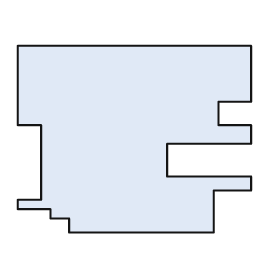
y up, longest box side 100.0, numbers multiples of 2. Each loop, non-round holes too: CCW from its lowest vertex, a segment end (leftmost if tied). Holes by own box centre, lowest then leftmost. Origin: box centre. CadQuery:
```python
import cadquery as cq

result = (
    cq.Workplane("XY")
    .moveTo(-28.0, -40.0)
    .lineTo(34.0, -40.0)
    .lineTo(34.0, -22.0)
    .lineTo(50.0, -22.0)
    .lineTo(50.0, -16.0)
    .lineTo(14.0, -16.0)
    .lineTo(14.0, -2.0)
    .lineTo(50.0, -2.0)
    .lineTo(50.0, 6.0)
    .lineTo(36.0, 6.0)
    .lineTo(36.0, 16.0)
    .lineTo(50.0, 16.0)
    .lineTo(50.0, 40.0)
    .lineTo(-50.0, 40.0)
    .lineTo(-50.0, 6.0)
    .lineTo(-40.0, 6.0)
    .lineTo(-40.0, -26.0)
    .lineTo(-50.0, -26.0)
    .lineTo(-50.0, -30.0)
    .lineTo(-36.0, -30.0)
    .lineTo(-36.0, -34.0)
    .lineTo(-28.0, -34.0)
    .close()
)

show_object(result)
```